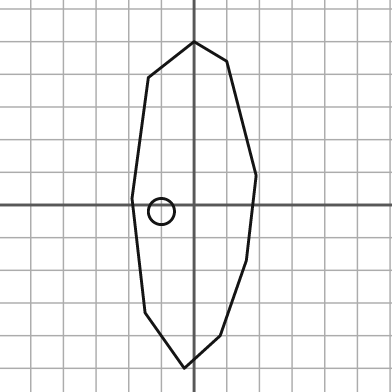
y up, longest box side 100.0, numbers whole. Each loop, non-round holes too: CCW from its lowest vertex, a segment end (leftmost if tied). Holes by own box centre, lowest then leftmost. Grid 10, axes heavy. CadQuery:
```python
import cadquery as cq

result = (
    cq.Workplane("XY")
    .moveTo(-3.0, -50.0)
    .lineTo(8.0, -40.0)
    .lineTo(16.0, -17.0)
    .lineTo(19.0, 9.0)
    .lineTo(10.0, 44.0)
    .lineTo(0.0, 50.0)
    .lineTo(-14.0, 39.0)
    .lineTo(-19.0, 2.0)
    .lineTo(-15.0, -33.0)
    .close()
    .moveTo(-10.0, -2.0)
    .circle(4.0)
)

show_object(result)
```